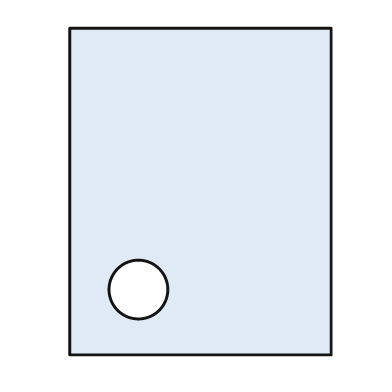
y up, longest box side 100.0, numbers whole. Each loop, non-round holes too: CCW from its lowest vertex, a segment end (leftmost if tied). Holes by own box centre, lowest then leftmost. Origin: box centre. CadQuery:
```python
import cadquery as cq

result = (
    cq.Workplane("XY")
    .moveTo(-40.0, -50.0)
    .lineTo(40.0, -50.0)
    .lineTo(40.0, 50.0)
    .lineTo(-40.0, 50.0)
    .close()
    .moveTo(-19.0, -30.0)
    .circle(9.0)
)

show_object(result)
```